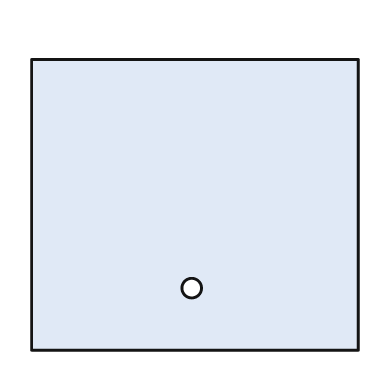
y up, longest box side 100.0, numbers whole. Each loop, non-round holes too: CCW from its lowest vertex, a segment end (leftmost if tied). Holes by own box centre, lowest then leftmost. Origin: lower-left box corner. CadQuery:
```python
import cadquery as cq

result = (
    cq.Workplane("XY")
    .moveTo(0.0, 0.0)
    .lineTo(100.0, 0.0)
    .lineTo(100.0, 89.0)
    .lineTo(0.0, 89.0)
    .close()
    .moveTo(49.0, 19.0)
    .circle(3.0)
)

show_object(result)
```